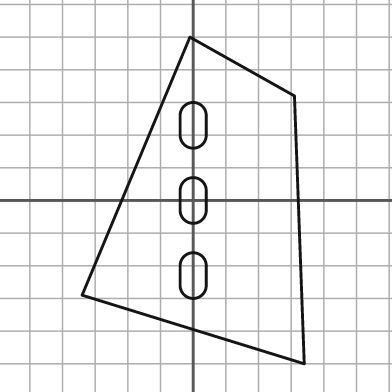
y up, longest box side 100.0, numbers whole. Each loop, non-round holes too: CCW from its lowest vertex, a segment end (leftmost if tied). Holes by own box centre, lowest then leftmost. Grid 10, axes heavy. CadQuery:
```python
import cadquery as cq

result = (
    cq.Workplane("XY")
    .moveTo(34.0, -50.0)
    .lineTo(31.0, 32.0)
    .lineTo(-1.0, 50.0)
    .lineTo(-34.0, -29.0)
    .close()
    .moveTo(-4.0, -26.0)
    .threePointArc((0.0, -30.0), (4.0, -26.0))
    .lineTo(4.0, -20.0)
    .threePointArc((0.0, -16.0), (-4.0, -20.0))
    .close()
    .moveTo(-4.0, -3.0)
    .threePointArc((0.0, -7.0), (4.0, -3.0))
    .lineTo(4.0, 3.0)
    .threePointArc((0.0, 7.0), (-4.0, 3.0))
    .close()
    .moveTo(-4.0, 20.0)
    .threePointArc((0.0, 16.0), (4.0, 20.0))
    .lineTo(4.0, 26.0)
    .threePointArc((0.0, 30.0), (-4.0, 26.0))
    .close()
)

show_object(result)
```